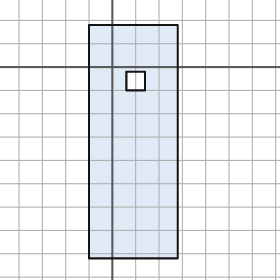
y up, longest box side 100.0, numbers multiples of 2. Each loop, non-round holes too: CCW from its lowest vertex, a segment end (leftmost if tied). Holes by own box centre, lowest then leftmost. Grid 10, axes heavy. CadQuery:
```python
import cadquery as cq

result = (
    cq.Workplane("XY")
    .moveTo(-10.0, -82.0)
    .lineTo(28.0, -82.0)
    .lineTo(28.0, 18.0)
    .lineTo(-10.0, 18.0)
    .close()
    .moveTo(6.0, -10.0)
    .lineTo(14.0, -10.0)
    .lineTo(14.0, -2.0)
    .lineTo(6.0, -2.0)
    .close()
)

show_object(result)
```